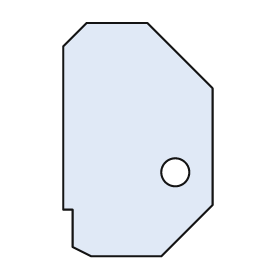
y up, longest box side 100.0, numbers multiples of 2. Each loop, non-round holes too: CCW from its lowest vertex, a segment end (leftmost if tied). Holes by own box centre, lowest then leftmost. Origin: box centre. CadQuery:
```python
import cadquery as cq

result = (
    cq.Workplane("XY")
    .moveTo(-20.0, -50.0)
    .lineTo(10.0, -50.0)
    .lineTo(32.0, -28.0)
    .lineTo(32.0, 22.0)
    .lineTo(4.0, 50.0)
    .lineTo(-22.0, 50.0)
    .lineTo(-32.0, 40.0)
    .lineTo(-32.0, -30.0)
    .lineTo(-28.0, -30.0)
    .lineTo(-28.0, -46.0)
    .close()
    .moveTo(16.0, -14.0)
    .circle(6.0)
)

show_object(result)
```